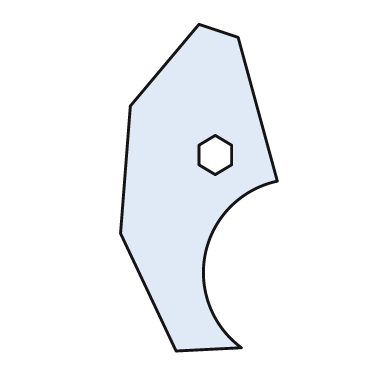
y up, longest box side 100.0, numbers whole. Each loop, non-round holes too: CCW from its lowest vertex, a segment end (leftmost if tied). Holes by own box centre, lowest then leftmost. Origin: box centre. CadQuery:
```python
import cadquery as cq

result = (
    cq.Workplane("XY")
    .moveTo(-7.0, -50.0)
    .lineTo(13.0, -49.0)
    .threePointArc((2.0, -20.0), (24.0, 2.0))
    .lineTo(12.0, 46.0)
    .lineTo(0.0, 50.0)
    .lineTo(-21.0, 25.0)
    .lineTo(-24.0, -14.0)
    .close()
    .moveTo(5.0, 4.0)
    .lineTo(10.0, 7.0)
    .lineTo(10.0, 13.0)
    .lineTo(5.0, 16.0)
    .lineTo(0.0, 13.0)
    .lineTo(0.0, 7.0)
    .close()
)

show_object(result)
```